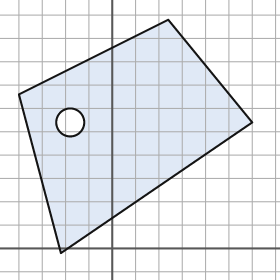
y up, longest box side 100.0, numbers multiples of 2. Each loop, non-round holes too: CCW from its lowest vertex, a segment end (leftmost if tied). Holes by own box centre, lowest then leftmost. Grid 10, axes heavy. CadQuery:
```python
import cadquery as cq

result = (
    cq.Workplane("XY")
    .moveTo(-22.0, -2.0)
    .lineTo(60.0, 54.0)
    .lineTo(24.0, 98.0)
    .lineTo(-40.0, 66.0)
    .close()
    .moveTo(-18.0, 54.0)
    .circle(6.0)
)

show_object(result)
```